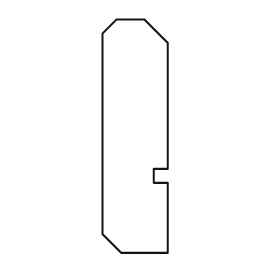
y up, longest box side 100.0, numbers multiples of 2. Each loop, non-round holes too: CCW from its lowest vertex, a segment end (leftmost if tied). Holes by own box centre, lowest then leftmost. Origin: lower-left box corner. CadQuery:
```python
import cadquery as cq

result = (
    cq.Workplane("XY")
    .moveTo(8.0, 0.0)
    .lineTo(28.0, 0.0)
    .lineTo(28.0, 30.0)
    .lineTo(22.0, 30.0)
    .lineTo(22.0, 36.0)
    .lineTo(28.0, 36.0)
    .lineTo(28.0, 90.0)
    .lineTo(18.0, 100.0)
    .lineTo(6.0, 100.0)
    .lineTo(0.0, 94.0)
    .lineTo(0.0, 8.0)
    .close()
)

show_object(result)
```